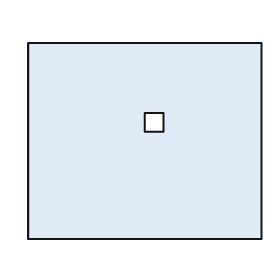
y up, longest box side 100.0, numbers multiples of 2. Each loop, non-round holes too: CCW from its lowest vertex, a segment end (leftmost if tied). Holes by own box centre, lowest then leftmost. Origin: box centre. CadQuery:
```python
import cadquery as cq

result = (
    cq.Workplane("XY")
    .moveTo(-50.0, -42.0)
    .lineTo(50.0, -42.0)
    .lineTo(50.0, 42.0)
    .lineTo(-50.0, 42.0)
    .close()
    .moveTo(0.0, 4.0)
    .lineTo(8.0, 4.0)
    .lineTo(8.0, 12.0)
    .lineTo(0.0, 12.0)
    .close()
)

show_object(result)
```